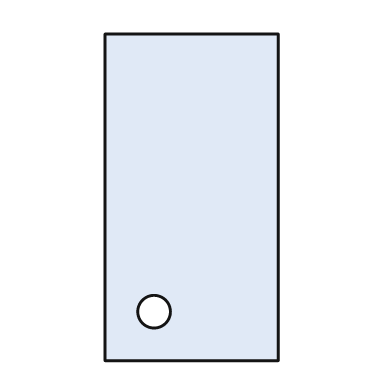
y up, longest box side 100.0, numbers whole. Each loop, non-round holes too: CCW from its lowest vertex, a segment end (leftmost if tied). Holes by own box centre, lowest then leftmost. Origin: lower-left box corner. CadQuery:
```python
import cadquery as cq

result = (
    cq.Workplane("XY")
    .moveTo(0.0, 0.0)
    .lineTo(53.0, 0.0)
    .lineTo(53.0, 100.0)
    .lineTo(0.0, 100.0)
    .close()
    .moveTo(15.0, 15.0)
    .circle(5.0)
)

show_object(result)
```